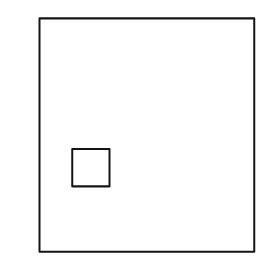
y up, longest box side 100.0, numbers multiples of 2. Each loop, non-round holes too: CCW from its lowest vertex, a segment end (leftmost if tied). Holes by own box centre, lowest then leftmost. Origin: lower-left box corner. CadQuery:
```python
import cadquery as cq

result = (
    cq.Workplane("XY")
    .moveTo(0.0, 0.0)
    .lineTo(92.0, 0.0)
    .lineTo(92.0, 100.0)
    .lineTo(0.0, 100.0)
    .close()
    .moveTo(14.0, 28.0)
    .lineTo(30.0, 28.0)
    .lineTo(30.0, 44.0)
    .lineTo(14.0, 44.0)
    .close()
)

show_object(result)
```